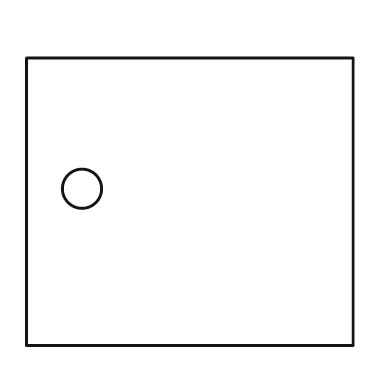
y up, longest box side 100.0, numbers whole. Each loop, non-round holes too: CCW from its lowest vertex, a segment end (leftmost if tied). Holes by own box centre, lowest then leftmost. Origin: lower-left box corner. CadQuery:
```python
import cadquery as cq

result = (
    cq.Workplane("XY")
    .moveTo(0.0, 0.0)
    .lineTo(100.0, 0.0)
    .lineTo(100.0, 88.0)
    .lineTo(0.0, 88.0)
    .close()
    .moveTo(17.0, 48.0)
    .circle(6.0)
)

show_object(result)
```